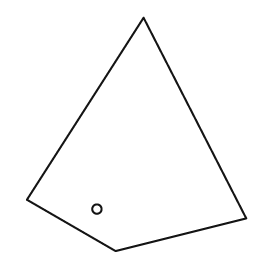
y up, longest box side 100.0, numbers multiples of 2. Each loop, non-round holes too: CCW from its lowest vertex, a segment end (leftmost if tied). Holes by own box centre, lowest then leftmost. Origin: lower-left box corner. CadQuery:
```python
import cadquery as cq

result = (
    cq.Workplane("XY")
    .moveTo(38.0, 0.0)
    .lineTo(94.0, 14.0)
    .lineTo(50.0, 100.0)
    .lineTo(0.0, 22.0)
    .close()
    .moveTo(30.0, 18.0)
    .circle(2.0)
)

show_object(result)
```